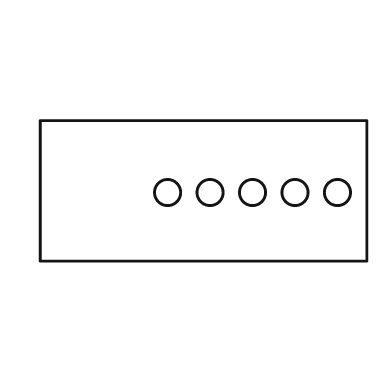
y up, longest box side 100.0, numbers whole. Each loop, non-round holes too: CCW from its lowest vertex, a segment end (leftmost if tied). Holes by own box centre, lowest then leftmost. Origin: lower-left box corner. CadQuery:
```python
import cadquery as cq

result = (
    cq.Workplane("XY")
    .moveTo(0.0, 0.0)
    .lineTo(100.0, 0.0)
    .lineTo(100.0, 43.0)
    .lineTo(0.0, 43.0)
    .close()
    .moveTo(39.0, 21.0)
    .circle(4.0)
    .moveTo(52.0, 21.0)
    .circle(4.0)
    .moveTo(65.0, 21.0)
    .circle(4.0)
    .moveTo(78.0, 21.0)
    .circle(4.0)
    .moveTo(91.0, 21.0)
    .circle(4.0)
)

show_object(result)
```